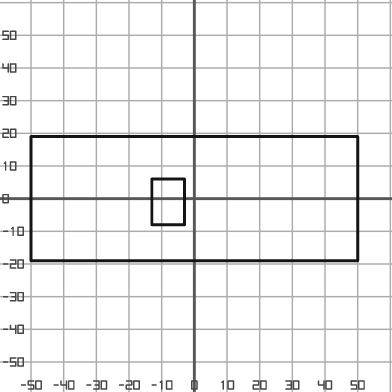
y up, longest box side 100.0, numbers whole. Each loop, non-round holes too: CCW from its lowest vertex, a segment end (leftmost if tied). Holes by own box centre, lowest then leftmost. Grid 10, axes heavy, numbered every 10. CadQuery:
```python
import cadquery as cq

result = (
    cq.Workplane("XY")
    .moveTo(-50.0, -19.0)
    .lineTo(50.0, -19.0)
    .lineTo(50.0, 19.0)
    .lineTo(-50.0, 19.0)
    .close()
    .moveTo(-13.0, -8.0)
    .lineTo(-3.0, -8.0)
    .lineTo(-3.0, 6.0)
    .lineTo(-13.0, 6.0)
    .close()
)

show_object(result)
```